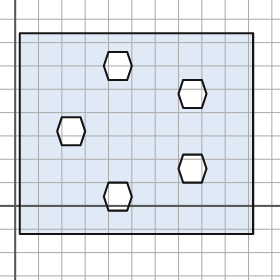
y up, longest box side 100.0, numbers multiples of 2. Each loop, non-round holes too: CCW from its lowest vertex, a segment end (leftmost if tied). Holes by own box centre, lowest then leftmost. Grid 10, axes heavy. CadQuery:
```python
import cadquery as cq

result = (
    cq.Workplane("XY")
    .moveTo(2.0, -12.0)
    .lineTo(102.0, -12.0)
    .lineTo(102.0, 74.0)
    .lineTo(2.0, 74.0)
    .close()
    .moveTo(40.0, -2.0)
    .lineTo(48.0, -2.0)
    .lineTo(50.0, 4.0)
    .lineTo(48.0, 10.0)
    .lineTo(40.0, 10.0)
    .lineTo(38.0, 4.0)
    .close()
    .moveTo(72.0, 10.0)
    .lineTo(80.0, 10.0)
    .lineTo(82.0, 16.0)
    .lineTo(80.0, 22.0)
    .lineTo(72.0, 22.0)
    .lineTo(70.0, 16.0)
    .close()
    .moveTo(20.0, 26.0)
    .lineTo(28.0, 26.0)
    .lineTo(30.0, 32.0)
    .lineTo(28.0, 38.0)
    .lineTo(20.0, 38.0)
    .lineTo(18.0, 32.0)
    .close()
    .moveTo(72.0, 42.0)
    .lineTo(80.0, 42.0)
    .lineTo(82.0, 48.0)
    .lineTo(80.0, 54.0)
    .lineTo(72.0, 54.0)
    .lineTo(70.0, 48.0)
    .close()
    .moveTo(40.0, 54.0)
    .lineTo(48.0, 54.0)
    .lineTo(50.0, 60.0)
    .lineTo(48.0, 66.0)
    .lineTo(40.0, 66.0)
    .lineTo(38.0, 60.0)
    .close()
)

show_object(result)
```